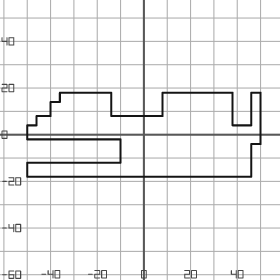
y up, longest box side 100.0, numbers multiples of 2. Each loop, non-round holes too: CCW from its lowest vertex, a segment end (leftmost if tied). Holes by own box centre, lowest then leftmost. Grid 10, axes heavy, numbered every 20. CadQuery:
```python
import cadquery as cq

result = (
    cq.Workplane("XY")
    .moveTo(-50.0, -18.0)
    .lineTo(46.0, -18.0)
    .lineTo(46.0, -4.0)
    .lineTo(50.0, -4.0)
    .lineTo(50.0, 18.0)
    .lineTo(46.0, 18.0)
    .lineTo(46.0, 4.0)
    .lineTo(38.0, 4.0)
    .lineTo(38.0, 18.0)
    .lineTo(8.0, 18.0)
    .lineTo(8.0, 8.0)
    .lineTo(-14.0, 8.0)
    .lineTo(-14.0, 18.0)
    .lineTo(-36.0, 18.0)
    .lineTo(-36.0, 14.0)
    .lineTo(-40.0, 14.0)
    .lineTo(-40.0, 8.0)
    .lineTo(-46.0, 8.0)
    .lineTo(-46.0, 4.0)
    .lineTo(-50.0, 4.0)
    .lineTo(-50.0, -2.0)
    .lineTo(-10.0, -2.0)
    .lineTo(-10.0, -12.0)
    .lineTo(-50.0, -12.0)
    .close()
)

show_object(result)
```